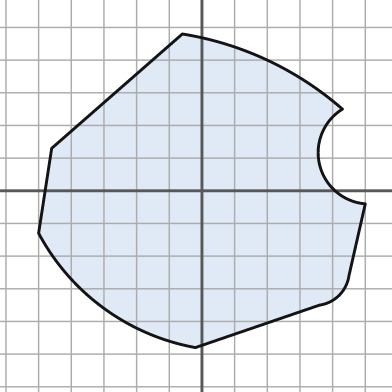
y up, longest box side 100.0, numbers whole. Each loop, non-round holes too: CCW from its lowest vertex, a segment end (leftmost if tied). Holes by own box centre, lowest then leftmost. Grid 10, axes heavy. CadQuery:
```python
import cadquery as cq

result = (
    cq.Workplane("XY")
    .moveTo(-2.0, -48.0)
    .lineTo(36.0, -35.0)
    .threePointArc((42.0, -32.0), (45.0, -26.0))
    .lineTo(50.0, -4.0)
    .threePointArc((36.0, 8.0), (43.0, 25.0))
    .threePointArc((20.0, 40.0), (-6.0, 48.0))
    .lineTo(-46.0, 13.0)
    .lineTo(-50.0, -13.0)
    .threePointArc((-30.0, -36.0), (-2.0, -48.0))
    .close()
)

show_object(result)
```